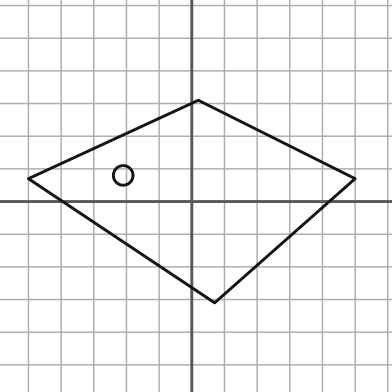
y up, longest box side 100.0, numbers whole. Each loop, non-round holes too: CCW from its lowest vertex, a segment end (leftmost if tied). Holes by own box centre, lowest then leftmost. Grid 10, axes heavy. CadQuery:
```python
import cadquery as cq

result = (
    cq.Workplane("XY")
    .moveTo(7.0, -31.0)
    .lineTo(50.0, 7.0)
    .lineTo(2.0, 31.0)
    .lineTo(-50.0, 7.0)
    .close()
    .moveTo(-21.0, 8.0)
    .circle(3.0)
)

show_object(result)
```